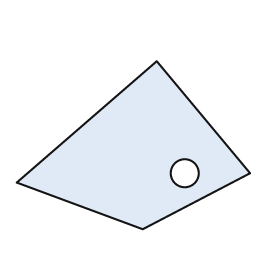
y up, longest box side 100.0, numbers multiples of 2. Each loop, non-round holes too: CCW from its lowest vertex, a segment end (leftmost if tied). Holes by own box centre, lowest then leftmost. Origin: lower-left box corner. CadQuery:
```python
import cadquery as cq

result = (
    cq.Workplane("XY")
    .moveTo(54.0, 0.0)
    .lineTo(100.0, 24.0)
    .lineTo(60.0, 72.0)
    .lineTo(0.0, 20.0)
    .close()
    .moveTo(72.0, 24.0)
    .circle(6.0)
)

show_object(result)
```